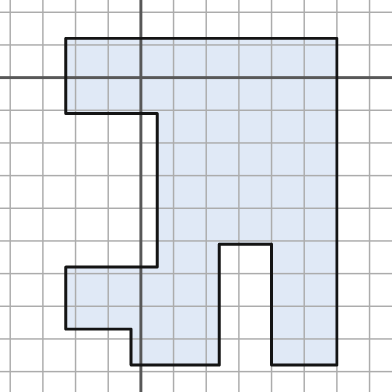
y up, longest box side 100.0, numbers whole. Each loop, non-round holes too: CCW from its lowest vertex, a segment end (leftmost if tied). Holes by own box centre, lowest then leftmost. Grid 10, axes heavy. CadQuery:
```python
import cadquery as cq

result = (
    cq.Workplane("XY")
    .moveTo(-3.0, -88.0)
    .lineTo(24.0, -88.0)
    .lineTo(24.0, -51.0)
    .lineTo(40.0, -51.0)
    .lineTo(40.0, -88.0)
    .lineTo(60.0, -88.0)
    .lineTo(60.0, 12.0)
    .lineTo(-23.0, 12.0)
    .lineTo(-23.0, -11.0)
    .lineTo(5.0, -11.0)
    .lineTo(5.0, -58.0)
    .lineTo(-23.0, -58.0)
    .lineTo(-23.0, -77.0)
    .lineTo(-3.0, -77.0)
    .close()
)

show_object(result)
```